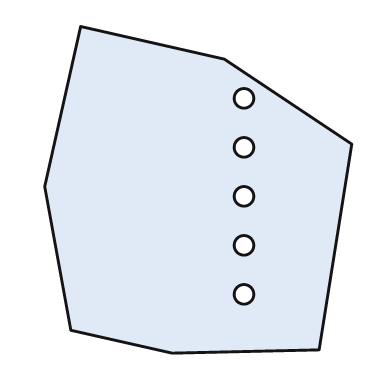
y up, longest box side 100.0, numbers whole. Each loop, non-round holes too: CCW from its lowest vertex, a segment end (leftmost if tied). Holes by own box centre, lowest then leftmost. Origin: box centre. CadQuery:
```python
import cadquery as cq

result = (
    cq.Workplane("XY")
    .moveTo(-8.0, -50.0)
    .lineTo(37.0, -49.0)
    .lineTo(47.0, 14.0)
    .lineTo(8.0, 40.0)
    .lineTo(-36.0, 50.0)
    .lineTo(-47.0, 1.0)
    .lineTo(-39.0, -43.0)
    .close()
    .moveTo(14.0, -32.0)
    .circle(3.0)
    .moveTo(14.0, -17.0)
    .circle(3.0)
    .moveTo(14.0, -2.0)
    .circle(3.0)
    .moveTo(14.0, 13.0)
    .circle(3.0)
    .moveTo(14.0, 28.0)
    .circle(3.0)
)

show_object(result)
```